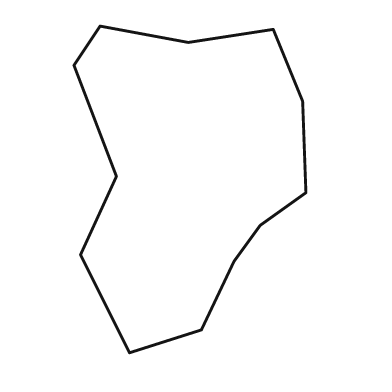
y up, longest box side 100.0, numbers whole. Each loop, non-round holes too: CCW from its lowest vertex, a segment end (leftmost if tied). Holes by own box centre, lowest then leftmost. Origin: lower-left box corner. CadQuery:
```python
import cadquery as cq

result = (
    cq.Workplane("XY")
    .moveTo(17.0, 0.0)
    .lineTo(39.0, 7.0)
    .lineTo(49.0, 28.0)
    .lineTo(57.0, 39.0)
    .lineTo(71.0, 49.0)
    .lineTo(70.0, 77.0)
    .lineTo(61.0, 99.0)
    .lineTo(35.0, 95.0)
    .lineTo(8.0, 100.0)
    .lineTo(0.0, 88.0)
    .lineTo(13.0, 54.0)
    .lineTo(2.0, 30.0)
    .close()
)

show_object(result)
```